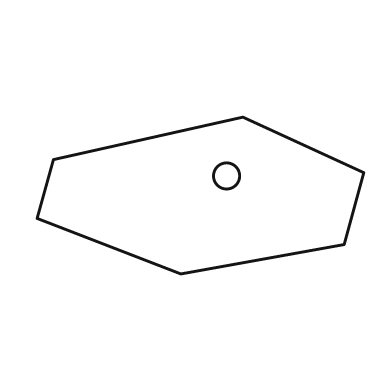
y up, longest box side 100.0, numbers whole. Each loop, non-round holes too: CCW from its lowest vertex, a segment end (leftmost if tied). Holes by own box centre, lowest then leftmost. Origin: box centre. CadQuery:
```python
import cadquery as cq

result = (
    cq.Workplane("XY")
    .moveTo(-6.0, -24.0)
    .lineTo(44.0, -15.0)
    .lineTo(50.0, 7.0)
    .lineTo(13.0, 24.0)
    .lineTo(-45.0, 11.0)
    .lineTo(-50.0, -7.0)
    .close()
    .moveTo(8.0, 6.0)
    .circle(4.0)
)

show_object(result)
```